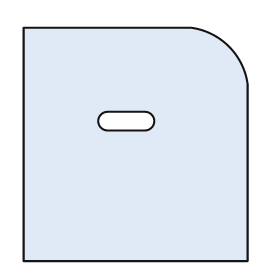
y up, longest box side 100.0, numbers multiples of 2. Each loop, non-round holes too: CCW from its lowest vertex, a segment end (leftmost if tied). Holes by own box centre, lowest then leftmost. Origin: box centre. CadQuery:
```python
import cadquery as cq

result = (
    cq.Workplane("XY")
    .moveTo(-48.0, -50.0)
    .lineTo(48.0, -50.0)
    .lineTo(48.0, 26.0)
    .threePointArc((40.0, 42.0), (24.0, 50.0))
    .lineTo(-48.0, 50.0)
    .close()
    .moveTo(-12.0, 6.0)
    .lineTo(4.0, 6.0)
    .threePointArc((8.0, 10.0), (4.0, 14.0))
    .lineTo(-12.0, 14.0)
    .threePointArc((-16.0, 10.0), (-12.0, 6.0))
    .close()
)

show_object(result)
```